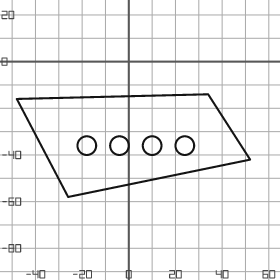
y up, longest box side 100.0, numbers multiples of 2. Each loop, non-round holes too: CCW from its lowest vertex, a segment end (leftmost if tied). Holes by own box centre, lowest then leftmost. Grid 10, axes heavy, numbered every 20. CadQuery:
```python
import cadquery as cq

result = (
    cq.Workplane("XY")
    .moveTo(-26.0, -58.0)
    .lineTo(52.0, -42.0)
    .lineTo(34.0, -14.0)
    .lineTo(-48.0, -16.0)
    .close()
    .moveTo(-18.0, -36.0)
    .circle(4.0)
    .moveTo(-4.0, -36.0)
    .circle(4.0)
    .moveTo(10.0, -36.0)
    .circle(4.0)
    .moveTo(24.0, -36.0)
    .circle(4.0)
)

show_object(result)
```